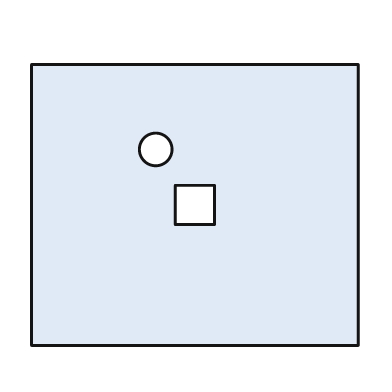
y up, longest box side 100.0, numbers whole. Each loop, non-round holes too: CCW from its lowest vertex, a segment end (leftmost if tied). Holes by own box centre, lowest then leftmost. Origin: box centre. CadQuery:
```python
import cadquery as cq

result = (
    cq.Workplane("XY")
    .moveTo(-50.0, -43.0)
    .lineTo(50.0, -43.0)
    .lineTo(50.0, 43.0)
    .lineTo(-50.0, 43.0)
    .close()
    .moveTo(-6.0, -6.0)
    .lineTo(6.0, -6.0)
    .lineTo(6.0, 6.0)
    .lineTo(-6.0, 6.0)
    .close()
    .moveTo(-12.0, 17.0)
    .circle(5.0)
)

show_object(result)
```